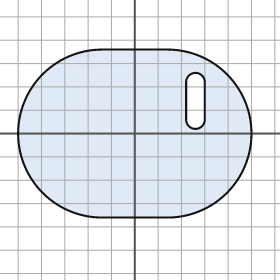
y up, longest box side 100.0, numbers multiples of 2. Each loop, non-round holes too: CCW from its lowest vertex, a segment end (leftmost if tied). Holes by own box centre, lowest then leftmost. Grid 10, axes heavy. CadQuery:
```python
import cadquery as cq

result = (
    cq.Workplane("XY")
    .moveTo(-14.0, -36.0)
    .lineTo(14.0, -36.0)
    .threePointArc((50.0, 0.0), (14.0, 36.0))
    .lineTo(-14.0, 36.0)
    .threePointArc((-50.0, 0.0), (-14.0, -36.0))
    .close()
    .moveTo(22.0, 6.0)
    .threePointArc((26.0, 2.0), (30.0, 6.0))
    .lineTo(30.0, 22.0)
    .threePointArc((26.0, 26.0), (22.0, 22.0))
    .close()
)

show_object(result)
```